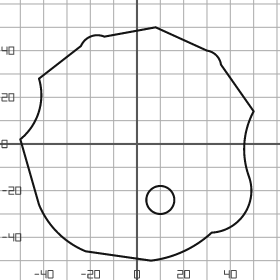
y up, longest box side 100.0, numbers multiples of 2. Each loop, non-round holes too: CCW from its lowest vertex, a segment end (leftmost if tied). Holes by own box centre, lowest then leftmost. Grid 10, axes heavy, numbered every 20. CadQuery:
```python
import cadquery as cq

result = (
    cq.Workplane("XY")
    .moveTo(6.0, -50.0)
    .threePointArc((20.0, -46.0), (32.0, -38.0))
    .threePointArc((46.0, -30.0), (48.0, -14.0))
    .threePointArc((46.0, 0.0), (50.0, 14.0))
    .lineTo(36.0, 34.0)
    .threePointArc((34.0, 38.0), (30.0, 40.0))
    .lineTo(8.0, 50.0)
    .lineTo(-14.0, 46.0)
    .threePointArc((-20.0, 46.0), (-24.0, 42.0))
    .lineTo(-42.0, 28.0)
    .threePointArc((-42.0, 14.0), (-50.0, 2.0))
    .lineTo(-42.0, -26.0)
    .threePointArc((-34.0, -38.0), (-22.0, -46.0))
    .close()
    .moveTo(10.0, -24.0)
    .circle(6.0)
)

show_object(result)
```